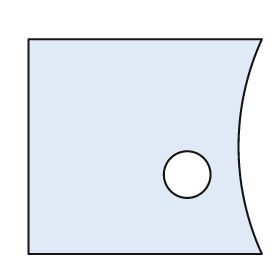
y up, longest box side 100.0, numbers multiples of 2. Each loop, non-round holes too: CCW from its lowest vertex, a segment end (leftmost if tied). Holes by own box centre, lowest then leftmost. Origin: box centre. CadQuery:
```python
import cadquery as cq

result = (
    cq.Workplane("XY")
    .moveTo(-50.0, -46.0)
    .lineTo(50.0, -46.0)
    .threePointArc((40.0, 0.0), (50.0, 46.0))
    .lineTo(-50.0, 46.0)
    .close()
    .moveTo(18.0, -12.0)
    .circle(10.0)
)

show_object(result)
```